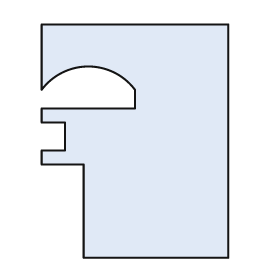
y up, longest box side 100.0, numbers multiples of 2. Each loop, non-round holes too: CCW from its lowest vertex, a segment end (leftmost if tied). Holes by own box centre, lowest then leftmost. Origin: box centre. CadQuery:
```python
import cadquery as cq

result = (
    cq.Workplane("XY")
    .moveTo(-22.0, -50.0)
    .lineTo(40.0, -50.0)
    .lineTo(40.0, 50.0)
    .lineTo(-40.0, 50.0)
    .lineTo(-40.0, 22.0)
    .threePointArc((-20.0, 32.0), (0.0, 22.0))
    .lineTo(0.0, 14.0)
    .lineTo(-40.0, 14.0)
    .lineTo(-40.0, 8.0)
    .lineTo(-30.0, 8.0)
    .lineTo(-30.0, -4.0)
    .lineTo(-40.0, -4.0)
    .lineTo(-40.0, -10.0)
    .lineTo(-22.0, -10.0)
    .close()
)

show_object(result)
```